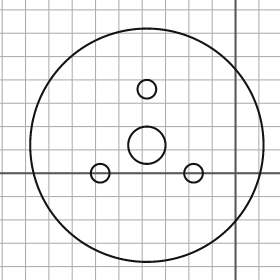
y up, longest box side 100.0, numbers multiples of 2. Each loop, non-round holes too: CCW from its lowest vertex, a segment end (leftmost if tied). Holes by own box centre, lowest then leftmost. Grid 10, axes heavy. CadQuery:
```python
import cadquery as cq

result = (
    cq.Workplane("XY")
    .moveTo(-38.0, 12.0)
    .circle(50.0)
    .moveTo(-58.0, 0.0)
    .circle(4.0)
    .moveTo(-18.0, 0.0)
    .circle(4.0)
    .moveTo(-38.0, 12.0)
    .circle(8.0)
    .moveTo(-38.0, 36.0)
    .circle(4.0)
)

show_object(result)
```